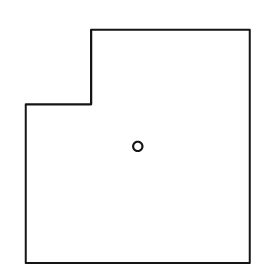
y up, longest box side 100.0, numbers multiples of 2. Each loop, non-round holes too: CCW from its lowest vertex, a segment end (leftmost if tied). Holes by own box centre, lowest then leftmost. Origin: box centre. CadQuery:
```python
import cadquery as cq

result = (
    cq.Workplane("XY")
    .moveTo(-48.0, -50.0)
    .lineTo(48.0, -50.0)
    .lineTo(48.0, 50.0)
    .lineTo(-20.0, 50.0)
    .lineTo(-20.0, 18.0)
    .lineTo(-48.0, 18.0)
    .close()
    .moveTo(0.0, 0.0)
    .circle(2.0)
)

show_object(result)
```